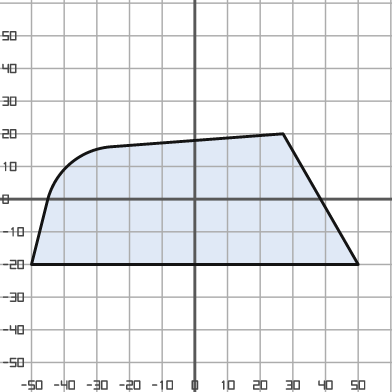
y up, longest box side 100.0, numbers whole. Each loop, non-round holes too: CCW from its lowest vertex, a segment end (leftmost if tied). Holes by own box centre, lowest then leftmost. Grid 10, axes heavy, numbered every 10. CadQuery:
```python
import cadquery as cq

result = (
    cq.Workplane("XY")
    .moveTo(-50.0, -20.0)
    .lineTo(50.0, -20.0)
    .lineTo(27.0, 20.0)
    .lineTo(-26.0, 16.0)
    .threePointArc((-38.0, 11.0), (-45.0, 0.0))
    .close()
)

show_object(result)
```